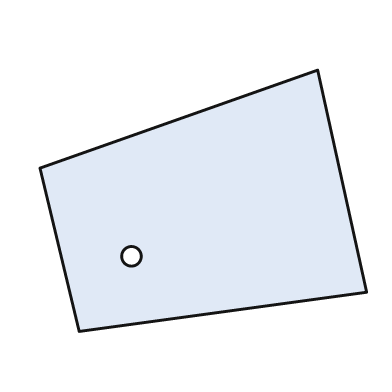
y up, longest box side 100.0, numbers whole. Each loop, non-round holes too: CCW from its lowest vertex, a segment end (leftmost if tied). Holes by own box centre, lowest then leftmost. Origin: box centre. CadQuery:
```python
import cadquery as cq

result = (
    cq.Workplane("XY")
    .moveTo(-38.0, -40.0)
    .lineTo(50.0, -28.0)
    .lineTo(35.0, 40.0)
    .lineTo(-50.0, 10.0)
    .close()
    .moveTo(-22.0, -17.0)
    .circle(3.0)
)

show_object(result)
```